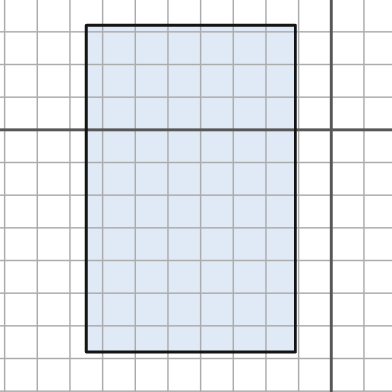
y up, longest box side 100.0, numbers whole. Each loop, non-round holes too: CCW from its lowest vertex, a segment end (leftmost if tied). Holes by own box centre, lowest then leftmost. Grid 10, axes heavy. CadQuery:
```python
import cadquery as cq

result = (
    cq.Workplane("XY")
    .moveTo(-75.0, -68.0)
    .lineTo(-11.0, -68.0)
    .lineTo(-11.0, 32.0)
    .lineTo(-75.0, 32.0)
    .close()
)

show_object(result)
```